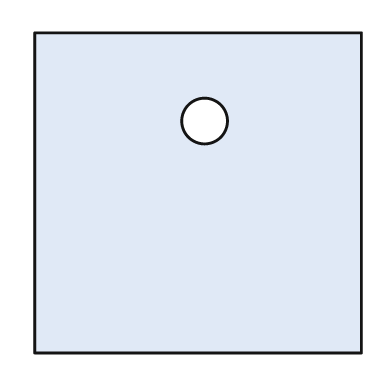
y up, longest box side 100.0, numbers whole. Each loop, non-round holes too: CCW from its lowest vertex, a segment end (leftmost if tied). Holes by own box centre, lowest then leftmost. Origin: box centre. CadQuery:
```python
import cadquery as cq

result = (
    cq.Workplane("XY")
    .moveTo(-50.0, -49.0)
    .lineTo(50.0, -49.0)
    .lineTo(50.0, 49.0)
    .lineTo(-50.0, 49.0)
    .close()
    .moveTo(2.0, 22.0)
    .circle(7.0)
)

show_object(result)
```